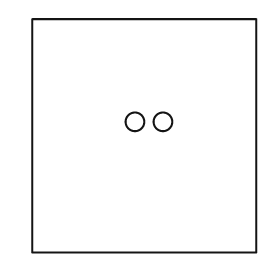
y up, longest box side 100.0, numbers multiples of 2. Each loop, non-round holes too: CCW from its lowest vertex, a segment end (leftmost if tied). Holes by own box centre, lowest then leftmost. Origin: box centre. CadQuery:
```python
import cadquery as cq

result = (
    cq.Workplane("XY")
    .moveTo(-48.0, -50.0)
    .lineTo(48.0, -50.0)
    .lineTo(48.0, 50.0)
    .lineTo(-48.0, 50.0)
    .close()
    .moveTo(-4.0, 6.0)
    .circle(4.0)
    .moveTo(8.0, 6.0)
    .circle(4.0)
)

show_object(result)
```